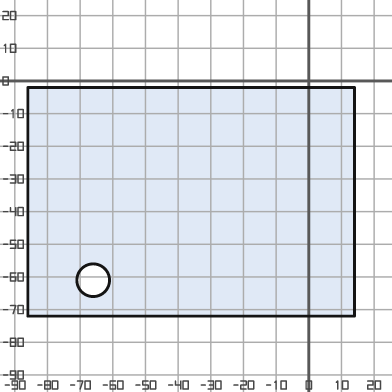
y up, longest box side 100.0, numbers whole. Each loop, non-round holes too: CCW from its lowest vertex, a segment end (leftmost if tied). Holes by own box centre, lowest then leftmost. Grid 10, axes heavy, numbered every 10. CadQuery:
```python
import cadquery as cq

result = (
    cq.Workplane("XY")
    .moveTo(-86.0, -72.0)
    .lineTo(14.0, -72.0)
    .lineTo(14.0, -2.0)
    .lineTo(-86.0, -2.0)
    .close()
    .moveTo(-66.0, -61.0)
    .circle(5.0)
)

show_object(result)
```